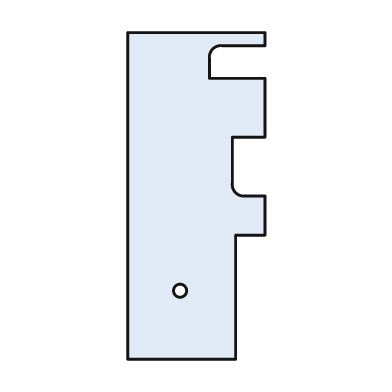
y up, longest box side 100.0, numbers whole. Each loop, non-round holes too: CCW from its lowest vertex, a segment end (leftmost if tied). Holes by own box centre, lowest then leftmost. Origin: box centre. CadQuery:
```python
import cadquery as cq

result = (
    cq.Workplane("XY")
    .moveTo(-21.0, -50.0)
    .lineTo(12.0, -50.0)
    .lineTo(12.0, -12.0)
    .lineTo(21.0, -12.0)
    .lineTo(21.0, 0.0)
    .lineTo(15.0, 0.0)
    .threePointArc((12.0, 1.0), (11.0, 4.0))
    .lineTo(11.0, 18.0)
    .lineTo(21.0, 18.0)
    .lineTo(21.0, 36.0)
    .lineTo(4.0, 36.0)
    .lineTo(4.0, 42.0)
    .threePointArc((5.0, 45.0), (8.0, 46.0))
    .lineTo(21.0, 46.0)
    .lineTo(21.0, 50.0)
    .lineTo(-21.0, 50.0)
    .close()
    .moveTo(-5.0, -29.0)
    .circle(2.0)
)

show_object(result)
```